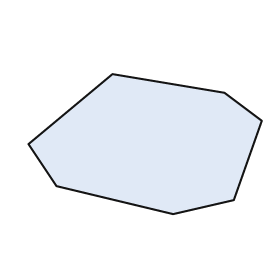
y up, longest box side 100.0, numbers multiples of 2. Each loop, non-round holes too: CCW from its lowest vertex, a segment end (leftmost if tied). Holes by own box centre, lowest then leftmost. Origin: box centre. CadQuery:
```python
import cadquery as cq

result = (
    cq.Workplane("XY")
    .moveTo(12.0, -30.0)
    .lineTo(38.0, -24.0)
    .lineTo(50.0, 10.0)
    .lineTo(34.0, 22.0)
    .lineTo(-14.0, 30.0)
    .lineTo(-50.0, 0.0)
    .lineTo(-38.0, -18.0)
    .close()
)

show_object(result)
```